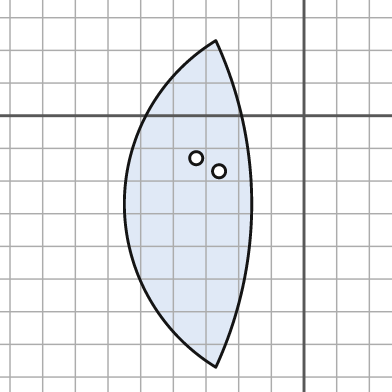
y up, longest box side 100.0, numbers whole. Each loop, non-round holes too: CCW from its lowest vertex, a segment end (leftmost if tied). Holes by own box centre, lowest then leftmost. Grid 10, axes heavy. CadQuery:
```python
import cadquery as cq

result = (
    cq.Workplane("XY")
    .moveTo(-27.0, -77.0)
    .threePointArc((-16.0, -27.0), (-27.0, 23.0))
    .threePointArc((-55.0, -27.0), (-27.0, -77.0))
    .close()
    .moveTo(-26.0, -17.0)
    .circle(2.0)
    .moveTo(-33.0, -13.0)
    .circle(2.0)
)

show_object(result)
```